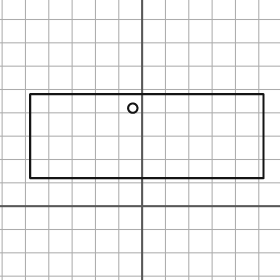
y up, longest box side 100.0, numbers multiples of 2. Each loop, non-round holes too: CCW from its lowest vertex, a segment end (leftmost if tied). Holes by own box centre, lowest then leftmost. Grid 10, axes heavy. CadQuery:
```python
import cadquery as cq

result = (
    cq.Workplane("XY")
    .moveTo(-48.0, 12.0)
    .lineTo(52.0, 12.0)
    .lineTo(52.0, 48.0)
    .lineTo(-48.0, 48.0)
    .close()
    .moveTo(-4.0, 42.0)
    .circle(2.0)
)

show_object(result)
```